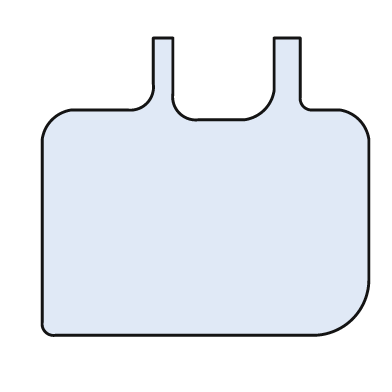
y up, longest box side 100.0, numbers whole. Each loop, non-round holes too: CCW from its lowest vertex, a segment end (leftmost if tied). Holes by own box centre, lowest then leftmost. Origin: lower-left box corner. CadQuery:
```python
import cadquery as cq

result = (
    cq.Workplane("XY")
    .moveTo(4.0, 0.0)
    .lineTo(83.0, 0.0)
    .threePointArc((95.0, 5.0), (100.0, 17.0))
    .lineTo(100.0, 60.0)
    .threePointArc((97.0, 66.0), (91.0, 69.0))
    .lineTo(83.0, 69.0)
    .threePointArc((80.0, 70.0), (79.0, 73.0))
    .lineTo(79.0, 91.0)
    .lineTo(71.0, 91.0)
    .lineTo(71.0, 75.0)
    .threePointArc((68.0, 69.0), (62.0, 66.0))
    .lineTo(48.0, 66.0)
    .threePointArc((42.0, 68.0), (40.0, 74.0))
    .lineTo(40.0, 91.0)
    .lineTo(34.0, 91.0)
    .lineTo(34.0, 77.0)
    .threePointArc((32.0, 71.0), (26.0, 69.0))
    .lineTo(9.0, 69.0)
    .threePointArc((3.0, 66.0), (0.0, 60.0))
    .lineTo(0.0, 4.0)
    .threePointArc((1.0, 1.0), (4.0, 0.0))
    .close()
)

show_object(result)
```